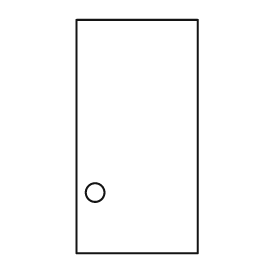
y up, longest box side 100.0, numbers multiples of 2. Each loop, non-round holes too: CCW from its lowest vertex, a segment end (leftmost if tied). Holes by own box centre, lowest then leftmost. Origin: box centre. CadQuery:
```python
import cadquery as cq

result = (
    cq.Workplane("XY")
    .moveTo(-26.0, -50.0)
    .lineTo(26.0, -50.0)
    .lineTo(26.0, 50.0)
    .lineTo(-26.0, 50.0)
    .close()
    .moveTo(-18.0, -24.0)
    .circle(4.0)
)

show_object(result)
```